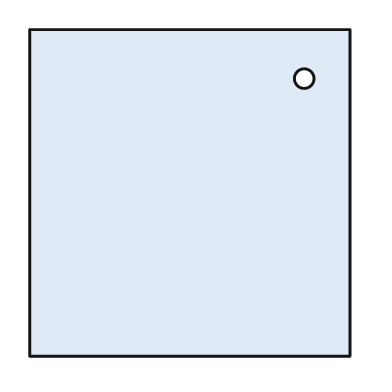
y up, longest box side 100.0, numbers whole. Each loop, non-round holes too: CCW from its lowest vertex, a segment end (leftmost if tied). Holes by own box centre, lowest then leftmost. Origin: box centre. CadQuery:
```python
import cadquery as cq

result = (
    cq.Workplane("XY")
    .moveTo(-49.0, -50.0)
    .lineTo(49.0, -50.0)
    .lineTo(49.0, 50.0)
    .lineTo(-49.0, 50.0)
    .close()
    .moveTo(35.0, 35.0)
    .circle(3.0)
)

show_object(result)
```